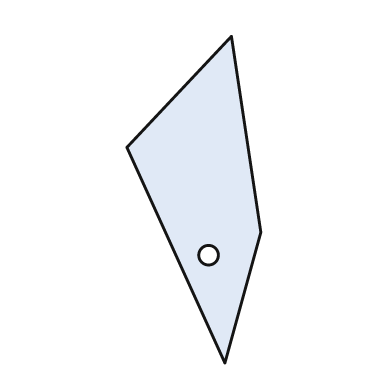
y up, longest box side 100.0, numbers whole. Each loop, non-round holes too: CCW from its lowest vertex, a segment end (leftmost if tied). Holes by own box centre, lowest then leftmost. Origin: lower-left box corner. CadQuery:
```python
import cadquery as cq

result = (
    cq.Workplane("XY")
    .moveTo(30.0, 0.0)
    .lineTo(41.0, 40.0)
    .lineTo(32.0, 100.0)
    .lineTo(0.0, 66.0)
    .close()
    .moveTo(25.0, 33.0)
    .circle(3.0)
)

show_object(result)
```